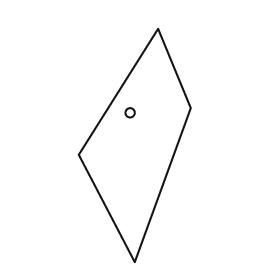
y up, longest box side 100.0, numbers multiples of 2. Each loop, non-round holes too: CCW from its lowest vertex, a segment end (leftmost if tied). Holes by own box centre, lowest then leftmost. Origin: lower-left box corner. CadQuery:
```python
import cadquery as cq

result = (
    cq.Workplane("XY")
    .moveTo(24.0, 0.0)
    .lineTo(48.0, 66.0)
    .lineTo(34.0, 100.0)
    .lineTo(0.0, 46.0)
    .close()
    .moveTo(22.0, 64.0)
    .circle(2.0)
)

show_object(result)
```